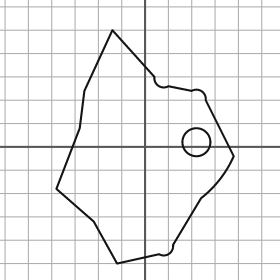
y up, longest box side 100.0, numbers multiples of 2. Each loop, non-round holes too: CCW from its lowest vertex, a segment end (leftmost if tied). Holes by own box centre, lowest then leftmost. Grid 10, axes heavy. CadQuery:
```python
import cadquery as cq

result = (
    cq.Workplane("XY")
    .moveTo(-12.0, -50.0)
    .lineTo(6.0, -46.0)
    .threePointArc((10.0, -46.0), (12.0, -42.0))
    .lineTo(24.0, -22.0)
    .threePointArc((32.0, -14.0), (38.0, -4.0))
    .lineTo(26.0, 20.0)
    .threePointArc((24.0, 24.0), (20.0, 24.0))
    .lineTo(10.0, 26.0)
    .threePointArc((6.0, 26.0), (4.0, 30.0))
    .lineTo(-14.0, 50.0)
    .lineTo(-26.0, 24.0)
    .lineTo(-28.0, 8.0)
    .lineTo(-38.0, -18.0)
    .lineTo(-22.0, -32.0)
    .close()
    .moveTo(22.0, 2.0)
    .circle(6.0)
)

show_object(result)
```